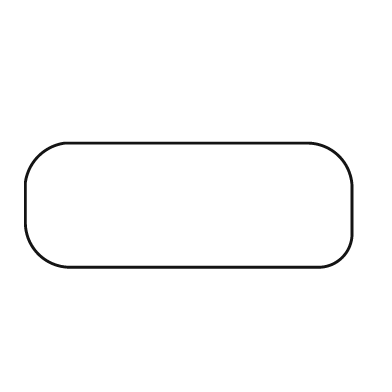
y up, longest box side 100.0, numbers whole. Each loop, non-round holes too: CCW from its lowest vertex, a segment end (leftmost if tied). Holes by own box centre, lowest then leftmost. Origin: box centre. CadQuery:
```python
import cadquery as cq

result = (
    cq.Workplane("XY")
    .moveTo(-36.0, -19.0)
    .lineTo(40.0, -19.0)
    .threePointArc((47.0, -16.0), (50.0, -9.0))
    .lineTo(50.0, 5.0)
    .threePointArc((46.0, 15.0), (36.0, 19.0))
    .lineTo(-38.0, 19.0)
    .threePointArc((-46.0, 15.0), (-50.0, 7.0))
    .lineTo(-50.0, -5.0)
    .threePointArc((-46.0, -15.0), (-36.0, -19.0))
    .close()
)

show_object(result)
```